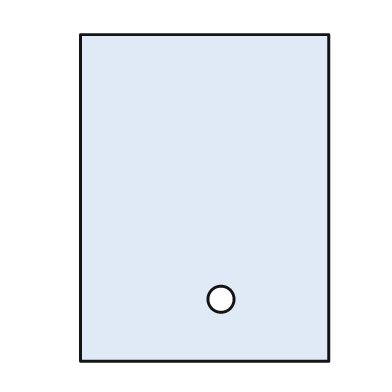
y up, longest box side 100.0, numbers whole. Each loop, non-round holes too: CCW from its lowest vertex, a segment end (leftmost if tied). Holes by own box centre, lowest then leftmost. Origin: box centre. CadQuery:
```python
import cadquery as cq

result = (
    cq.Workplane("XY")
    .moveTo(-38.0, -50.0)
    .lineTo(38.0, -50.0)
    .lineTo(38.0, 50.0)
    .lineTo(-38.0, 50.0)
    .close()
    .moveTo(5.0, -31.0)
    .circle(4.0)
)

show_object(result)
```